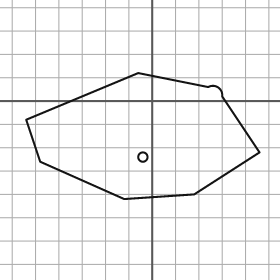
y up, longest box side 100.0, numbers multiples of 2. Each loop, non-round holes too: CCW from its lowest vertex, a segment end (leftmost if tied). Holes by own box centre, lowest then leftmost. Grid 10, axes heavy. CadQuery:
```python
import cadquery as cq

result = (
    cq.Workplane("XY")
    .moveTo(-12.0, -42.0)
    .lineTo(18.0, -40.0)
    .lineTo(46.0, -22.0)
    .lineTo(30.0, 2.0)
    .threePointArc((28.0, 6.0), (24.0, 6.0))
    .lineTo(-6.0, 12.0)
    .lineTo(-54.0, -8.0)
    .lineTo(-48.0, -26.0)
    .close()
    .moveTo(-4.0, -24.0)
    .circle(2.0)
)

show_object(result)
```